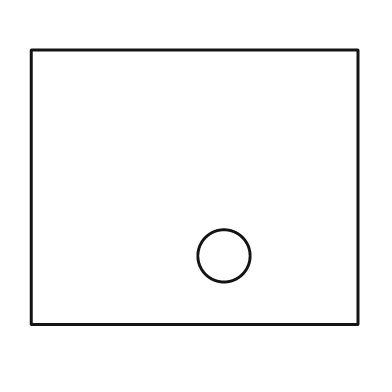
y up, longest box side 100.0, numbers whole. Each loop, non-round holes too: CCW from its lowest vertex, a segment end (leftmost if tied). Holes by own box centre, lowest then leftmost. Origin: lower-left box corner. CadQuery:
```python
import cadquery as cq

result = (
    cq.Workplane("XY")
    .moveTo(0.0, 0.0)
    .lineTo(100.0, 0.0)
    .lineTo(100.0, 84.0)
    .lineTo(0.0, 84.0)
    .close()
    .moveTo(59.0, 21.0)
    .circle(8.0)
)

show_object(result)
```